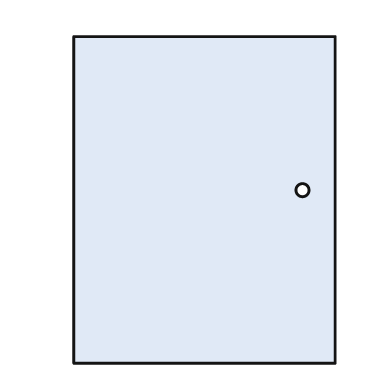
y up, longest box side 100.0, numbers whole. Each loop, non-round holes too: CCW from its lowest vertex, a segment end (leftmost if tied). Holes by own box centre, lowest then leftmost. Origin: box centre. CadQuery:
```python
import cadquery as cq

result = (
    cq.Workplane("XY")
    .moveTo(-40.0, -50.0)
    .lineTo(40.0, -50.0)
    .lineTo(40.0, 50.0)
    .lineTo(-40.0, 50.0)
    .close()
    .moveTo(30.0, 3.0)
    .circle(2.0)
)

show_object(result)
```